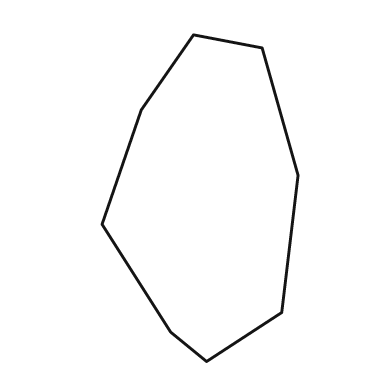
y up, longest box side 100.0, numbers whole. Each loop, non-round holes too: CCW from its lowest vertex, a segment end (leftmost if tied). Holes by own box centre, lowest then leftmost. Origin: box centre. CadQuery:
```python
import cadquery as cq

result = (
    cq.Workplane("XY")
    .moveTo(2.0, -50.0)
    .lineTo(25.0, -35.0)
    .lineTo(30.0, 7.0)
    .lineTo(19.0, 46.0)
    .lineTo(-2.0, 50.0)
    .lineTo(-18.0, 27.0)
    .lineTo(-30.0, -8.0)
    .lineTo(-9.0, -41.0)
    .close()
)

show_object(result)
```